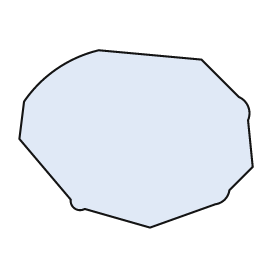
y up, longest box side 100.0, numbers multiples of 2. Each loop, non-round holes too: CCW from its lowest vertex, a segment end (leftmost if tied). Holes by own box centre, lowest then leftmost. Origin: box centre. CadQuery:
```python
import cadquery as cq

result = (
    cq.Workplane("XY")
    .moveTo(6.0, -38.0)
    .lineTo(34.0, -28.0)
    .threePointArc((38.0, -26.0), (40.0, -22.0))
    .lineTo(50.0, -12.0)
    .lineTo(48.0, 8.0)
    .threePointArc((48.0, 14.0), (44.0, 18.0))
    .lineTo(28.0, 34.0)
    .lineTo(-16.0, 38.0)
    .threePointArc((-34.0, 30.0), (-48.0, 16.0))
    .lineTo(-50.0, 0.0)
    .lineTo(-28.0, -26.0)
    .threePointArc((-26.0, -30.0), (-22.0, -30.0))
    .close()
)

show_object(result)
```